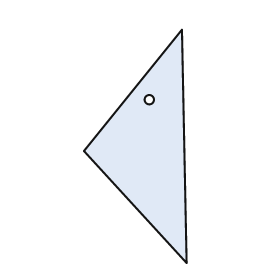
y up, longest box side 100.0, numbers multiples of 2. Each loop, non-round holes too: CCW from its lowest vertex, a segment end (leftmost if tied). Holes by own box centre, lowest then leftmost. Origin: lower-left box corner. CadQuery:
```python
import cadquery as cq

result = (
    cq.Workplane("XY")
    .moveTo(44.0, 0.0)
    .lineTo(42.0, 100.0)
    .lineTo(0.0, 48.0)
    .close()
    .moveTo(28.0, 70.0)
    .circle(2.0)
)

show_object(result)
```